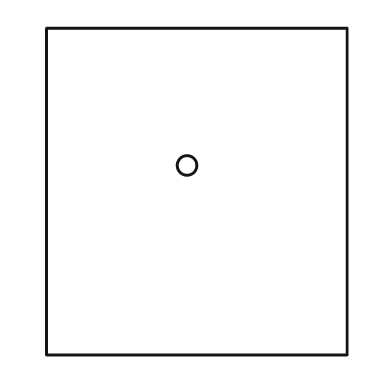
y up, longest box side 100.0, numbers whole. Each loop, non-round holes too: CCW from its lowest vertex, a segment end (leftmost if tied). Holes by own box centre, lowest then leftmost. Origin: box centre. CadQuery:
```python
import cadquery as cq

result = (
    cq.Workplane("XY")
    .moveTo(-46.0, -50.0)
    .lineTo(46.0, -50.0)
    .lineTo(46.0, 50.0)
    .lineTo(-46.0, 50.0)
    .close()
    .moveTo(-3.0, 8.0)
    .circle(3.0)
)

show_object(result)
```